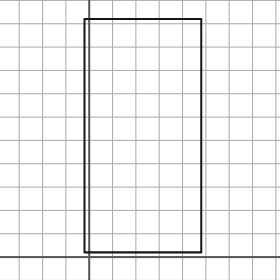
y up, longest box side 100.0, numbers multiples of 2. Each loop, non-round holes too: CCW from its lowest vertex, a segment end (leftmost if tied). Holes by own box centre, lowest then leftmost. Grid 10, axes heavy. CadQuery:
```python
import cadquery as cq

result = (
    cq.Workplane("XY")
    .moveTo(-2.0, 2.0)
    .lineTo(48.0, 2.0)
    .lineTo(48.0, 102.0)
    .lineTo(-2.0, 102.0)
    .close()
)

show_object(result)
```